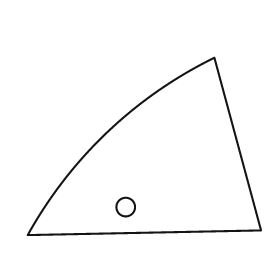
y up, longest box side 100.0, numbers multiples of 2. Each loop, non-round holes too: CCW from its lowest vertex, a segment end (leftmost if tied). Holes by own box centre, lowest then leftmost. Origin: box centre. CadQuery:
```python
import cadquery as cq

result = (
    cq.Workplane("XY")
    .moveTo(-50.0, -38.0)
    .lineTo(50.0, -36.0)
    .lineTo(30.0, 38.0)
    .threePointArc((-16.0, 6.0), (-50.0, -38.0))
    .close()
    .moveTo(-8.0, -26.0)
    .circle(4.0)
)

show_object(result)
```